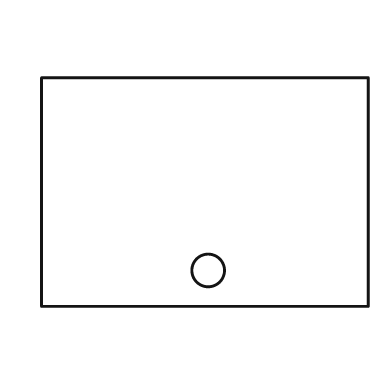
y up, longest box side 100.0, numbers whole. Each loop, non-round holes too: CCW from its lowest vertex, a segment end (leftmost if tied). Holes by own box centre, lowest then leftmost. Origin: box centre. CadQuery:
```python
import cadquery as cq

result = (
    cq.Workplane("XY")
    .moveTo(-50.0, -35.0)
    .lineTo(50.0, -35.0)
    .lineTo(50.0, 35.0)
    .lineTo(-50.0, 35.0)
    .close()
    .moveTo(1.0, -24.0)
    .circle(5.0)
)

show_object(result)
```